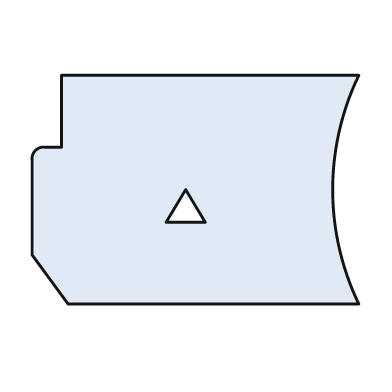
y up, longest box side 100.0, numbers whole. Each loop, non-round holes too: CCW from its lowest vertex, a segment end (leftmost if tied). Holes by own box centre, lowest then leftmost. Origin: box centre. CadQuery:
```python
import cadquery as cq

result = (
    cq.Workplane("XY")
    .moveTo(-39.0, -35.0)
    .lineTo(50.0, -35.0)
    .threePointArc((42.0, 0.0), (50.0, 35.0))
    .lineTo(-41.0, 35.0)
    .lineTo(-41.0, 13.0)
    .lineTo(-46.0, 13.0)
    .threePointArc((-49.0, 12.0), (-50.0, 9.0))
    .lineTo(-50.0, -20.0)
    .close()
    .moveTo(-9.0, -10.0)
    .lineTo(3.0, -10.0)
    .lineTo(-3.0, 0.0)
    .close()
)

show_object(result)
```